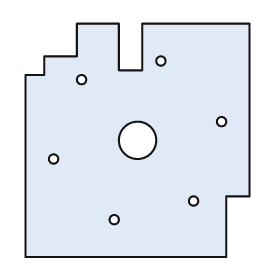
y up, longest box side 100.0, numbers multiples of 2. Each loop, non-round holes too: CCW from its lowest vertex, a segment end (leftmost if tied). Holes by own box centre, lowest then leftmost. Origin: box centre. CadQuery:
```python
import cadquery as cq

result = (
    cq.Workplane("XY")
    .moveTo(-48.0, -50.0)
    .lineTo(38.0, -50.0)
    .lineTo(38.0, -24.0)
    .lineTo(48.0, -24.0)
    .lineTo(48.0, 50.0)
    .lineTo(2.0, 50.0)
    .lineTo(2.0, 30.0)
    .lineTo(-8.0, 30.0)
    .lineTo(-8.0, 50.0)
    .lineTo(-26.0, 50.0)
    .lineTo(-26.0, 36.0)
    .lineTo(-40.0, 36.0)
    .lineTo(-40.0, 28.0)
    .lineTo(-48.0, 28.0)
    .close()
    .moveTo(-10.0, -34.0)
    .circle(2.0)
    .moveTo(24.0, -26.0)
    .circle(2.0)
    .moveTo(-36.0, -8.0)
    .circle(2.0)
    .moveTo(0.0, 0.0)
    .circle(8.0)
    .moveTo(36.0, 8.0)
    .circle(2.0)
    .moveTo(-24.0, 26.0)
    .circle(2.0)
    .moveTo(10.0, 34.0)
    .circle(2.0)
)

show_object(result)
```